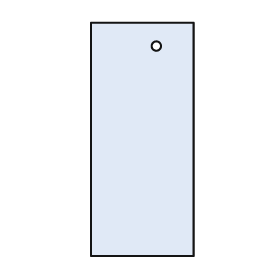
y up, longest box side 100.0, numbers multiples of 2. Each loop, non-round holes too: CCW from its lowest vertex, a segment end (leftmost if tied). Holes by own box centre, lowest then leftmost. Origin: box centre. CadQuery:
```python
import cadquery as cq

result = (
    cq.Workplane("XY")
    .moveTo(-22.0, -50.0)
    .lineTo(22.0, -50.0)
    .lineTo(22.0, 50.0)
    .lineTo(-22.0, 50.0)
    .close()
    .moveTo(6.0, 40.0)
    .circle(2.0)
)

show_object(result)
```